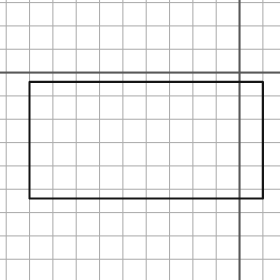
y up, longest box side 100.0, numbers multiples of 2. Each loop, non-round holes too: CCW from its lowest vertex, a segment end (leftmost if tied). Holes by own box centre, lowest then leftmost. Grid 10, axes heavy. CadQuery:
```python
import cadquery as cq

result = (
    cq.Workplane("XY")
    .moveTo(-90.0, -54.0)
    .lineTo(10.0, -54.0)
    .lineTo(10.0, -4.0)
    .lineTo(-90.0, -4.0)
    .close()
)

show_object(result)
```